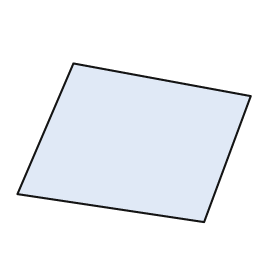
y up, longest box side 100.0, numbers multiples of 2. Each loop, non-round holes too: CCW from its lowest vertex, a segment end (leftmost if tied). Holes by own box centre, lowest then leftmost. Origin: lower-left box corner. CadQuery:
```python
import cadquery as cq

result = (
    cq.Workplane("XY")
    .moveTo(80.0, 0.0)
    .lineTo(100.0, 54.0)
    .lineTo(24.0, 68.0)
    .lineTo(0.0, 12.0)
    .close()
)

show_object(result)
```